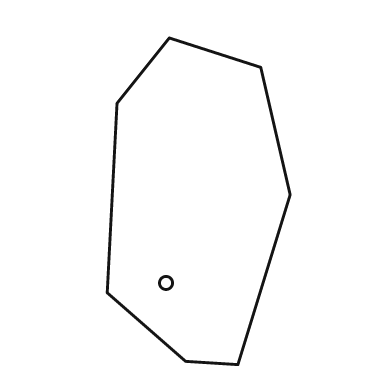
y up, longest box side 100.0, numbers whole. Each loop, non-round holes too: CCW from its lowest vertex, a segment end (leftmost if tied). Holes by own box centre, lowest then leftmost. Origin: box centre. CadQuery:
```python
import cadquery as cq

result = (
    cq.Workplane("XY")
    .moveTo(12.0, -50.0)
    .lineTo(28.0, 2.0)
    .lineTo(19.0, 41.0)
    .lineTo(-9.0, 50.0)
    .lineTo(-25.0, 30.0)
    .lineTo(-28.0, -28.0)
    .lineTo(-4.0, -49.0)
    .close()
    .moveTo(-10.0, -25.0)
    .circle(2.0)
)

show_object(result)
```